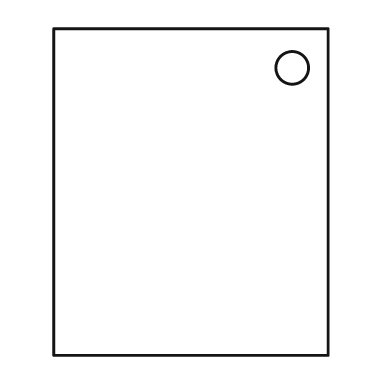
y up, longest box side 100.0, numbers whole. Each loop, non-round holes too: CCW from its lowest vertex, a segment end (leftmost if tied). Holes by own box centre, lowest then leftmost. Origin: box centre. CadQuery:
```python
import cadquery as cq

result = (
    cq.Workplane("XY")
    .moveTo(-42.0, -50.0)
    .lineTo(42.0, -50.0)
    .lineTo(42.0, 50.0)
    .lineTo(-42.0, 50.0)
    .close()
    .moveTo(31.0, 38.0)
    .circle(5.0)
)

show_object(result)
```